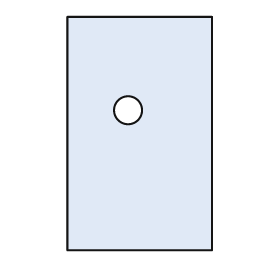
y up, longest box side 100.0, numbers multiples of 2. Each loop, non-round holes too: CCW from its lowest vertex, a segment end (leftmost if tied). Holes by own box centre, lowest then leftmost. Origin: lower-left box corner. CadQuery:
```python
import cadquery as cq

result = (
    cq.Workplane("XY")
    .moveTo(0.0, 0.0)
    .lineTo(62.0, 0.0)
    .lineTo(62.0, 100.0)
    .lineTo(0.0, 100.0)
    .close()
    .moveTo(26.0, 60.0)
    .circle(6.0)
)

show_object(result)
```